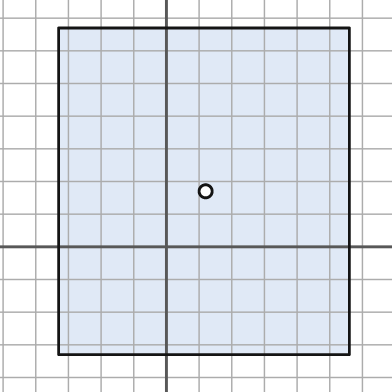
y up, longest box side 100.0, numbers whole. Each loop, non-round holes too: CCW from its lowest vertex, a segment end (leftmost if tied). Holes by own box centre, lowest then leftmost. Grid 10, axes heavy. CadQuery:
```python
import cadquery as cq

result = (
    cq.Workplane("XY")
    .moveTo(-33.0, -33.0)
    .lineTo(56.0, -33.0)
    .lineTo(56.0, 67.0)
    .lineTo(-33.0, 67.0)
    .close()
    .moveTo(12.0, 17.0)
    .circle(2.0)
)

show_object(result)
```